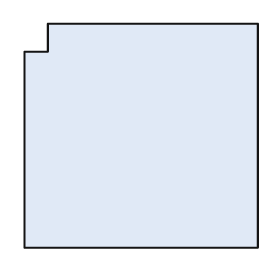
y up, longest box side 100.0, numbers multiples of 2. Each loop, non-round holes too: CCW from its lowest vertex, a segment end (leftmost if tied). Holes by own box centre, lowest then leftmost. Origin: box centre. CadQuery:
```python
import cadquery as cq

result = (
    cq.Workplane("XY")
    .moveTo(-50.0, -48.0)
    .lineTo(50.0, -48.0)
    .lineTo(50.0, 48.0)
    .lineTo(-40.0, 48.0)
    .lineTo(-40.0, 36.0)
    .lineTo(-50.0, 36.0)
    .close()
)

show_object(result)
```